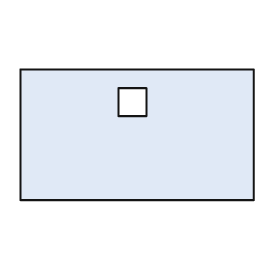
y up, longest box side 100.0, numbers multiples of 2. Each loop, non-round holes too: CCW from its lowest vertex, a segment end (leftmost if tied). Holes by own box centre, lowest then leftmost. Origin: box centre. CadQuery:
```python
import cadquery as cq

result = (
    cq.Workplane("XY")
    .moveTo(-50.0, -28.0)
    .lineTo(50.0, -28.0)
    .lineTo(50.0, 28.0)
    .lineTo(-50.0, 28.0)
    .close()
    .moveTo(-8.0, 8.0)
    .lineTo(4.0, 8.0)
    .lineTo(4.0, 20.0)
    .lineTo(-8.0, 20.0)
    .close()
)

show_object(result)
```